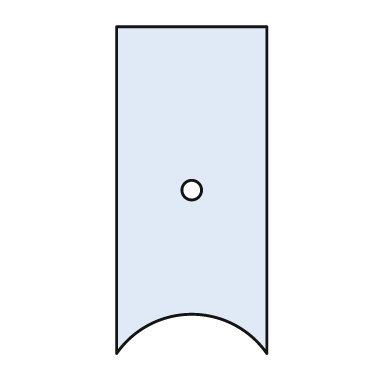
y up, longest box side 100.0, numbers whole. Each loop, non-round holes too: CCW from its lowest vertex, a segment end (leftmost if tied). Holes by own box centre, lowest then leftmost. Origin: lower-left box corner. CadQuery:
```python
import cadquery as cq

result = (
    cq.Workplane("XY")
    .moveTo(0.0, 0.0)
    .threePointArc((23.0, 12.0), (46.0, 0.0))
    .lineTo(46.0, 100.0)
    .lineTo(0.0, 100.0)
    .close()
    .moveTo(23.0, 50.0)
    .circle(3.0)
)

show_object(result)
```